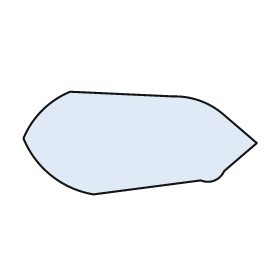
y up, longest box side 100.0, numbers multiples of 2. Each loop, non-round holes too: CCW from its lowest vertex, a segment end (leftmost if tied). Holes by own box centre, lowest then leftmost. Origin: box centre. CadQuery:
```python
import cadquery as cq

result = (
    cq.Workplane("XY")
    .moveTo(-20.0, -22.0)
    .lineTo(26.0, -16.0)
    .threePointArc((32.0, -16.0), (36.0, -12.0))
    .lineTo(50.0, 0.0)
    .lineTo(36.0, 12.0)
    .threePointArc((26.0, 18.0), (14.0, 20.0))
    .lineTo(-30.0, 22.0)
    .threePointArc((-42.0, 14.0), (-50.0, 2.0))
    .threePointArc((-38.0, -14.0), (-20.0, -22.0))
    .close()
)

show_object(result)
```